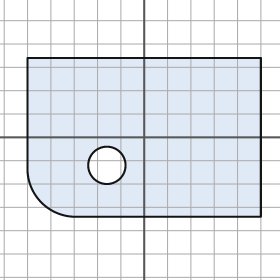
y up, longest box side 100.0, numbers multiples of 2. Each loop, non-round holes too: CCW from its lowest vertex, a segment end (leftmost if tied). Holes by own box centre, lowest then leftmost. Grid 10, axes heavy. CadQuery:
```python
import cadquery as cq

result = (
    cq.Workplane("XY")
    .moveTo(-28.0, -34.0)
    .lineTo(50.0, -34.0)
    .lineTo(50.0, 34.0)
    .lineTo(-50.0, 34.0)
    .lineTo(-50.0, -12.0)
    .threePointArc((-44.0, -28.0), (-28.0, -34.0))
    .close()
    .moveTo(-16.0, -12.0)
    .circle(8.0)
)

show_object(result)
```